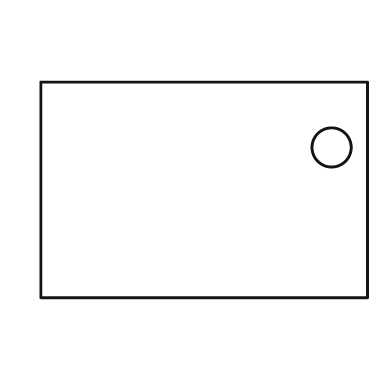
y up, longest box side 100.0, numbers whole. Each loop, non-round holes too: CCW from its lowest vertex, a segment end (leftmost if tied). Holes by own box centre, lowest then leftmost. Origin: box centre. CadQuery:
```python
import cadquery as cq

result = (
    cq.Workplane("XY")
    .moveTo(-50.0, -33.0)
    .lineTo(50.0, -33.0)
    .lineTo(50.0, 33.0)
    .lineTo(-50.0, 33.0)
    .close()
    .moveTo(39.0, 13.0)
    .circle(6.0)
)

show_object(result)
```